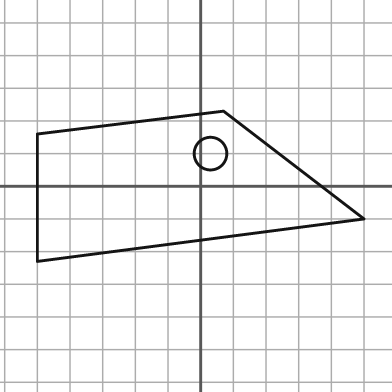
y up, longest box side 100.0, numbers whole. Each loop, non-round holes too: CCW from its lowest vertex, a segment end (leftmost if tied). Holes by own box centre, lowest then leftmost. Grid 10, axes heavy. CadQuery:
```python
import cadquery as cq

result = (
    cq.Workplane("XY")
    .moveTo(-50.0, -23.0)
    .lineTo(50.0, -10.0)
    .lineTo(7.0, 23.0)
    .lineTo(-50.0, 16.0)
    .close()
    .moveTo(3.0, 10.0)
    .circle(5.0)
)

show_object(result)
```